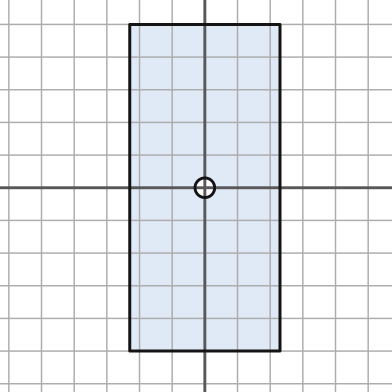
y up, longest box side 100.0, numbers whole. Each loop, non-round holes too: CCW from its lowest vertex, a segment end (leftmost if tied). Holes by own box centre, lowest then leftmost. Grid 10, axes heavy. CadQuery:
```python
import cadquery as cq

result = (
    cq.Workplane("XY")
    .moveTo(-23.0, -50.0)
    .lineTo(23.0, -50.0)
    .lineTo(23.0, 50.0)
    .lineTo(-23.0, 50.0)
    .close()
    .moveTo(0.0, 0.0)
    .circle(3.0)
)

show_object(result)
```